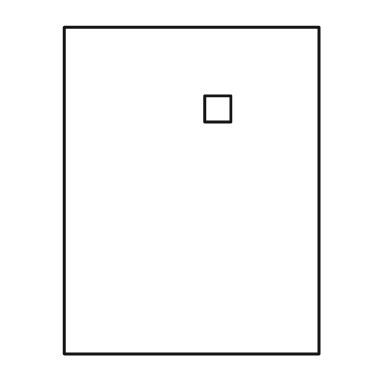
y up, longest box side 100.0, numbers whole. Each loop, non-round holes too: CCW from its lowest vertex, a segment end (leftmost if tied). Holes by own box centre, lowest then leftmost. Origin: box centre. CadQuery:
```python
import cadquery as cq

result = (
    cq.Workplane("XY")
    .moveTo(-39.0, -50.0)
    .lineTo(39.0, -50.0)
    .lineTo(39.0, 50.0)
    .lineTo(-39.0, 50.0)
    .close()
    .moveTo(4.0, 21.0)
    .lineTo(12.0, 21.0)
    .lineTo(12.0, 29.0)
    .lineTo(4.0, 29.0)
    .close()
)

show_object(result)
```